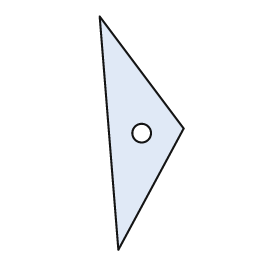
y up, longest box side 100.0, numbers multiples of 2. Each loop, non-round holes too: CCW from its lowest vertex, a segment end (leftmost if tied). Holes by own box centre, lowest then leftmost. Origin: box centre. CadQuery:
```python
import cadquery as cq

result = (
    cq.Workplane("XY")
    .moveTo(-10.0, -50.0)
    .lineTo(18.0, 2.0)
    .lineTo(-18.0, 50.0)
    .close()
    .moveTo(0.0, 0.0)
    .circle(4.0)
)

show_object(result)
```